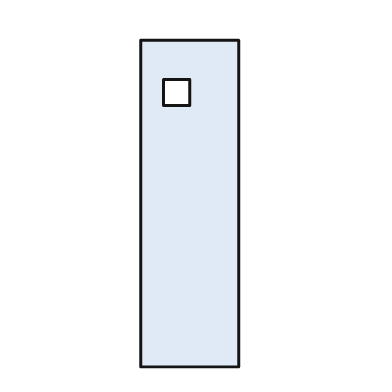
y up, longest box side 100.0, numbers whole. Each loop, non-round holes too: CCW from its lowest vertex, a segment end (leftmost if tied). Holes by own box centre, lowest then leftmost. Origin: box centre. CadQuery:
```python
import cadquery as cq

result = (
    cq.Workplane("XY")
    .moveTo(-15.0, -50.0)
    .lineTo(15.0, -50.0)
    .lineTo(15.0, 50.0)
    .lineTo(-15.0, 50.0)
    .close()
    .moveTo(-8.0, 30.0)
    .lineTo(0.0, 30.0)
    .lineTo(0.0, 38.0)
    .lineTo(-8.0, 38.0)
    .close()
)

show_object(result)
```